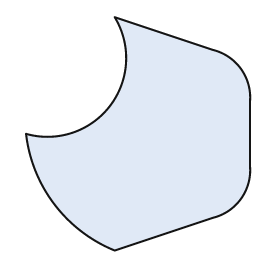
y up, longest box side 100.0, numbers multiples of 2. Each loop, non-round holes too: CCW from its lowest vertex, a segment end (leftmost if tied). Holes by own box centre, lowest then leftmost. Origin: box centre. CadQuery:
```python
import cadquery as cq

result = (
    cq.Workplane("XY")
    .moveTo(-10.0, -50.0)
    .lineTo(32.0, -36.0)
    .threePointArc((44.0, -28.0), (48.0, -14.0))
    .lineTo(48.0, 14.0)
    .threePointArc((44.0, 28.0), (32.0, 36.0))
    .lineTo(-10.0, 50.0)
    .threePointArc((-12.0, 12.0), (-48.0, 0.0))
    .threePointArc((-36.0, -30.0), (-10.0, -50.0))
    .close()
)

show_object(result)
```